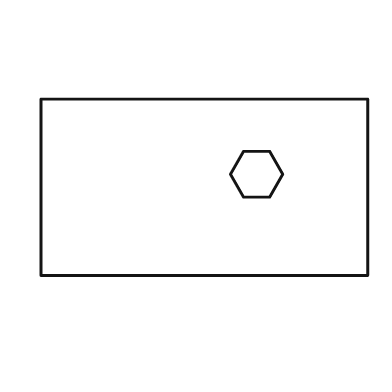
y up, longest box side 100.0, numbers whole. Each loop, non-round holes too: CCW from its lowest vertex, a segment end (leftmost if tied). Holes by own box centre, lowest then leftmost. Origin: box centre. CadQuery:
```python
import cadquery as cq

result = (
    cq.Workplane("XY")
    .moveTo(-50.0, -27.0)
    .lineTo(50.0, -27.0)
    .lineTo(50.0, 27.0)
    .lineTo(-50.0, 27.0)
    .close()
    .moveTo(12.0, -3.0)
    .lineTo(20.0, -3.0)
    .lineTo(24.0, 4.0)
    .lineTo(20.0, 11.0)
    .lineTo(12.0, 11.0)
    .lineTo(8.0, 4.0)
    .close()
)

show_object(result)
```